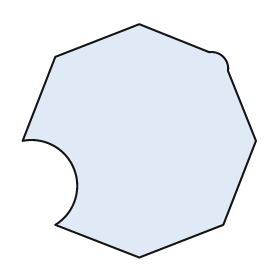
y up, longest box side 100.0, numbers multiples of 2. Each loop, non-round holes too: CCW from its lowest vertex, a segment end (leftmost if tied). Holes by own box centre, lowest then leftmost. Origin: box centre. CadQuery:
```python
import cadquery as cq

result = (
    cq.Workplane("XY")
    .moveTo(0.0, -50.0)
    .lineTo(36.0, -36.0)
    .lineTo(50.0, 0.0)
    .lineTo(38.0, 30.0)
    .threePointArc((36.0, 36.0), (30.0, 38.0))
    .lineTo(0.0, 50.0)
    .lineTo(-36.0, 36.0)
    .lineTo(-50.0, 0.0)
    .threePointArc((-28.0, -12.0), (-36.0, -36.0))
    .close()
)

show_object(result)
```